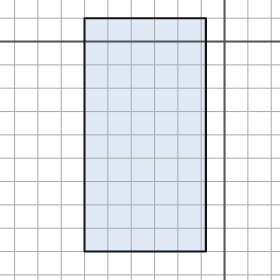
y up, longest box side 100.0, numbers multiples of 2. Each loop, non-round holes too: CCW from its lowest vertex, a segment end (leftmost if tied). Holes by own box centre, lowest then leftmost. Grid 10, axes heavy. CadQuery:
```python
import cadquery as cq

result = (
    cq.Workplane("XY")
    .moveTo(-60.0, -90.0)
    .lineTo(-8.0, -90.0)
    .lineTo(-8.0, 10.0)
    .lineTo(-60.0, 10.0)
    .close()
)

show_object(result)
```